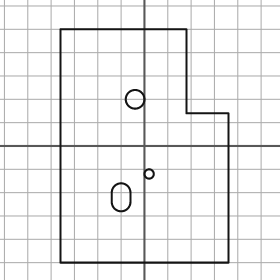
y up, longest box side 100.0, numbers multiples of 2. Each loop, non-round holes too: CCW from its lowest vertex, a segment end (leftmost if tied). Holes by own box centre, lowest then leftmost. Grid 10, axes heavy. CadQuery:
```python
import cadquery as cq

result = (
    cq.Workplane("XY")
    .moveTo(-36.0, -50.0)
    .lineTo(36.0, -50.0)
    .lineTo(36.0, 14.0)
    .lineTo(18.0, 14.0)
    .lineTo(18.0, 50.0)
    .lineTo(-36.0, 50.0)
    .close()
    .moveTo(-14.0, -24.0)
    .threePointArc((-10.0, -28.0), (-6.0, -24.0))
    .lineTo(-6.0, -20.0)
    .threePointArc((-10.0, -16.0), (-14.0, -20.0))
    .close()
    .moveTo(2.0, -12.0)
    .circle(2.0)
    .moveTo(-4.0, 20.0)
    .circle(4.0)
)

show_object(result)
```